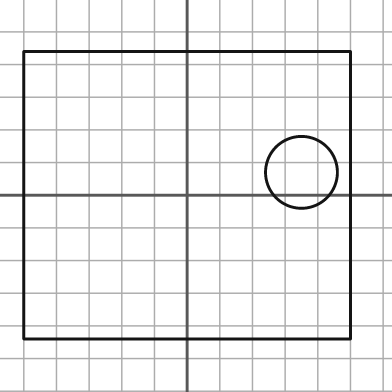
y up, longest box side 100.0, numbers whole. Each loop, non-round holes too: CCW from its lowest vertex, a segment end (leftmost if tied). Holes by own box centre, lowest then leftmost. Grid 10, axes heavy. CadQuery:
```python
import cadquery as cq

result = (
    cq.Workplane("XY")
    .moveTo(-50.0, -44.0)
    .lineTo(50.0, -44.0)
    .lineTo(50.0, 44.0)
    .lineTo(-50.0, 44.0)
    .close()
    .moveTo(35.0, 7.0)
    .circle(11.0)
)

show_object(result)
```